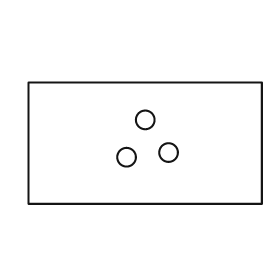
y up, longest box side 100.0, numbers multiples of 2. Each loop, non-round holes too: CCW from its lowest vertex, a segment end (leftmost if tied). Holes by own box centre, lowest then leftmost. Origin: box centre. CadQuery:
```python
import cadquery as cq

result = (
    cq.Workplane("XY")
    .moveTo(-50.0, -26.0)
    .lineTo(50.0, -26.0)
    .lineTo(50.0, 26.0)
    .lineTo(-50.0, 26.0)
    .close()
    .moveTo(-8.0, -6.0)
    .circle(4.0)
    .moveTo(10.0, -4.0)
    .circle(4.0)
    .moveTo(0.0, 10.0)
    .circle(4.0)
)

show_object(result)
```